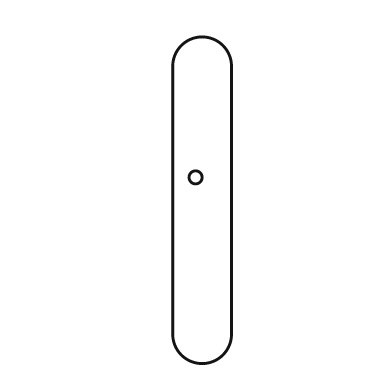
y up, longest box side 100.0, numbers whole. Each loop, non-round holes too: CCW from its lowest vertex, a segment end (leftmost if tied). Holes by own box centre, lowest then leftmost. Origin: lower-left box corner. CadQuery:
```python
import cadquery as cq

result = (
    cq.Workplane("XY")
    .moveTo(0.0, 9.0)
    .threePointArc((9.0, 0.0), (18.0, 9.0))
    .lineTo(18.0, 91.0)
    .threePointArc((9.0, 100.0), (0.0, 91.0))
    .close()
    .moveTo(7.0, 57.0)
    .circle(2.0)
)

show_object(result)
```